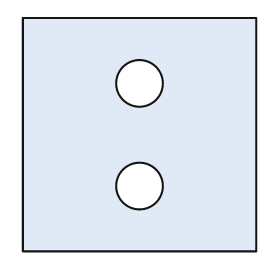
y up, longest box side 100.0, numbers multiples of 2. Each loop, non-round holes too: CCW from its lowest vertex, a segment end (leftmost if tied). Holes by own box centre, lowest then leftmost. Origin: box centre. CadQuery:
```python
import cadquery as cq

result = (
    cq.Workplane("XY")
    .moveTo(-50.0, -50.0)
    .lineTo(50.0, -50.0)
    .lineTo(50.0, 50.0)
    .lineTo(-50.0, 50.0)
    .close()
    .moveTo(0.0, -22.0)
    .circle(10.0)
    .moveTo(0.0, 22.0)
    .circle(10.0)
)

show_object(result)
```